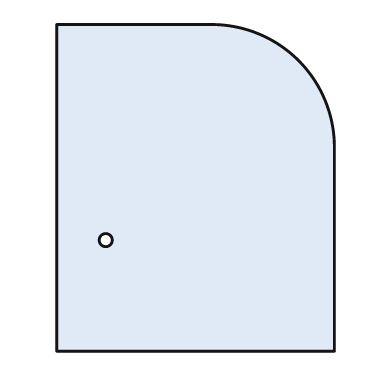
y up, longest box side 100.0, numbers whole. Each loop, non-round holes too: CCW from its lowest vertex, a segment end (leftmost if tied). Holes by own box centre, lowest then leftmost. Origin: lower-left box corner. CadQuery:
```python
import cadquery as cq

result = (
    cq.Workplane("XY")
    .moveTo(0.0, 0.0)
    .lineTo(85.0, 0.0)
    .lineTo(85.0, 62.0)
    .threePointArc((74.0, 89.0), (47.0, 100.0))
    .lineTo(0.0, 100.0)
    .close()
    .moveTo(15.0, 34.0)
    .circle(2.0)
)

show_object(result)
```